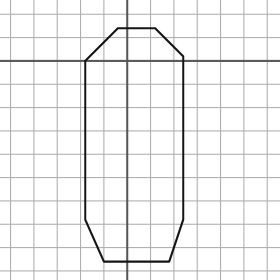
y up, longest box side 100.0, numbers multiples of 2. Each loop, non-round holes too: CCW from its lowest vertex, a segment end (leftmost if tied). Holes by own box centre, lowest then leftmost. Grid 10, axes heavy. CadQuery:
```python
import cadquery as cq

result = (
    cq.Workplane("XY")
    .moveTo(-10.0, -86.0)
    .lineTo(18.0, -86.0)
    .lineTo(24.0, -68.0)
    .lineTo(24.0, 2.0)
    .lineTo(12.0, 14.0)
    .lineTo(-4.0, 14.0)
    .lineTo(-18.0, 0.0)
    .lineTo(-18.0, -68.0)
    .close()
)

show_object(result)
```